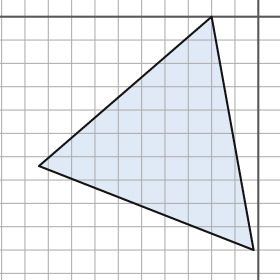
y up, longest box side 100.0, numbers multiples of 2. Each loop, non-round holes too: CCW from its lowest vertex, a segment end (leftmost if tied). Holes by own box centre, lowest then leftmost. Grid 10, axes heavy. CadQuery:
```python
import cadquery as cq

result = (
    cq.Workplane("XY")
    .moveTo(-2.0, -100.0)
    .lineTo(-20.0, 0.0)
    .lineTo(-94.0, -64.0)
    .close()
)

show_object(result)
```